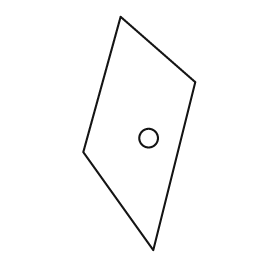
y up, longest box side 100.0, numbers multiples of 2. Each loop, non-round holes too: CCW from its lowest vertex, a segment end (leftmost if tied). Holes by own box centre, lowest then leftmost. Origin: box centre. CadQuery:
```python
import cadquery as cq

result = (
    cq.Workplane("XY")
    .moveTo(6.0, -50.0)
    .lineTo(24.0, 22.0)
    .lineTo(-8.0, 50.0)
    .lineTo(-24.0, -8.0)
    .close()
    .moveTo(4.0, -2.0)
    .circle(4.0)
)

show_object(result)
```